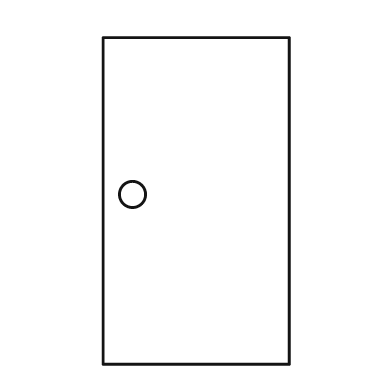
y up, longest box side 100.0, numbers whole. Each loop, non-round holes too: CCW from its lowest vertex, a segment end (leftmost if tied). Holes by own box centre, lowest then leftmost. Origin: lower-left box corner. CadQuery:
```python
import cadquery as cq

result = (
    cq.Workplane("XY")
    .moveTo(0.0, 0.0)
    .lineTo(57.0, 0.0)
    .lineTo(57.0, 100.0)
    .lineTo(0.0, 100.0)
    .close()
    .moveTo(9.0, 52.0)
    .circle(4.0)
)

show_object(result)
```